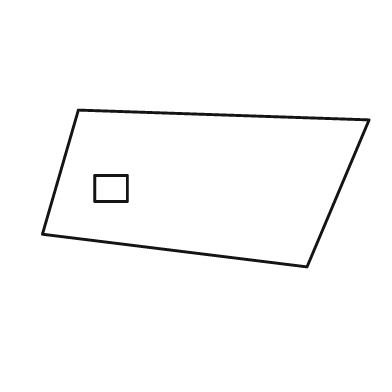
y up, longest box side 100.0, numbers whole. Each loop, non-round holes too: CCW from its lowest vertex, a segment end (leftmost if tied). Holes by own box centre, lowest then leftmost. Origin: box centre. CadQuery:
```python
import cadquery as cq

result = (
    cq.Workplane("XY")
    .moveTo(31.0, -24.0)
    .lineTo(50.0, 21.0)
    .lineTo(-39.0, 24.0)
    .lineTo(-50.0, -14.0)
    .close()
    .moveTo(-34.0, -4.0)
    .lineTo(-24.0, -4.0)
    .lineTo(-24.0, 4.0)
    .lineTo(-34.0, 4.0)
    .close()
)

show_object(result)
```